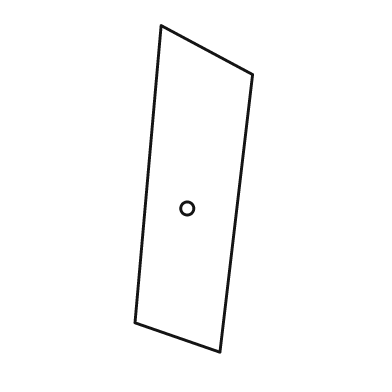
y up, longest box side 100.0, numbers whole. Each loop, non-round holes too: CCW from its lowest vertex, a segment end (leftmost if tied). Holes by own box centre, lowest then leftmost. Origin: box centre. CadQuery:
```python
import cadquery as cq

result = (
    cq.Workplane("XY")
    .moveTo(8.0, -50.0)
    .lineTo(18.0, 35.0)
    .lineTo(-10.0, 50.0)
    .lineTo(-18.0, -41.0)
    .close()
    .moveTo(-2.0, -6.0)
    .circle(2.0)
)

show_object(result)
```